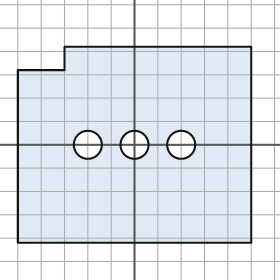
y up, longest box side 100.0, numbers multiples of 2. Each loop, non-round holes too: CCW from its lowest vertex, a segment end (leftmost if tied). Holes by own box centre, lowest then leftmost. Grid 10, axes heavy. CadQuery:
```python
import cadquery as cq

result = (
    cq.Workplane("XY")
    .moveTo(-50.0, -42.0)
    .lineTo(50.0, -42.0)
    .lineTo(50.0, 42.0)
    .lineTo(-30.0, 42.0)
    .lineTo(-30.0, 32.0)
    .lineTo(-50.0, 32.0)
    .close()
    .moveTo(-20.0, 0.0)
    .circle(6.0)
    .moveTo(0.0, 0.0)
    .circle(6.0)
    .moveTo(20.0, 0.0)
    .circle(6.0)
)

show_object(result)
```